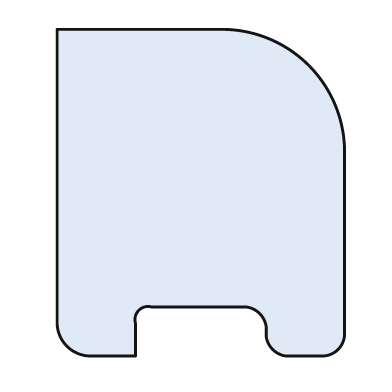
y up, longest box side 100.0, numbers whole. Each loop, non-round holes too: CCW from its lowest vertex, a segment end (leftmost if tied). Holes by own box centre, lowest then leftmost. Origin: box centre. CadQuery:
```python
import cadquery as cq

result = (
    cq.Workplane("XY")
    .moveTo(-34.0, -50.0)
    .lineTo(-20.0, -50.0)
    .lineTo(-20.0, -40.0)
    .threePointArc((-19.0, -36.0), (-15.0, -35.0))
    .lineTo(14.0, -35.0)
    .threePointArc((18.0, -37.0), (20.0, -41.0))
    .lineTo(20.0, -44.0)
    .threePointArc((22.0, -48.0), (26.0, -50.0))
    .lineTo(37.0, -50.0)
    .threePointArc((42.0, -48.0), (44.0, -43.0))
    .lineTo(44.0, 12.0)
    .threePointArc((33.0, 39.0), (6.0, 50.0))
    .lineTo(-44.0, 50.0)
    .lineTo(-44.0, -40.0)
    .threePointArc((-41.0, -47.0), (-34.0, -50.0))
    .close()
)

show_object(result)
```